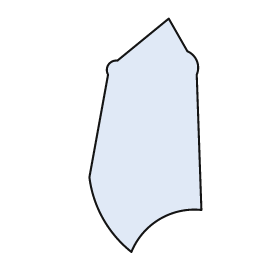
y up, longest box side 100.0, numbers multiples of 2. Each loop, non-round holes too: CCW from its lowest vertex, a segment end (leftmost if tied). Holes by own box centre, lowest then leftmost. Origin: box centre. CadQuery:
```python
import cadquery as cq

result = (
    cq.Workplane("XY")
    .moveTo(-6.0, -50.0)
    .threePointArc((6.0, -36.0), (24.0, -32.0))
    .lineTo(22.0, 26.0)
    .threePointArc((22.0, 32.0), (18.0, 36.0))
    .lineTo(10.0, 50.0)
    .lineTo(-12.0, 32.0)
    .threePointArc((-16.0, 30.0), (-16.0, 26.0))
    .lineTo(-24.0, -18.0)
    .threePointArc((-18.0, -36.0), (-6.0, -50.0))
    .close()
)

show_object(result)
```